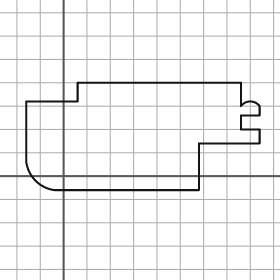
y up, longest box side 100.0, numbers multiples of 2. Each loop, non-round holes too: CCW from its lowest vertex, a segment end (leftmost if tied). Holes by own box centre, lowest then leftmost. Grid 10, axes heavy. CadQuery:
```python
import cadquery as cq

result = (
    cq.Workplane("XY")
    .moveTo(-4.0, -6.0)
    .lineTo(58.0, -6.0)
    .lineTo(58.0, 14.0)
    .lineTo(84.0, 14.0)
    .lineTo(84.0, 20.0)
    .lineTo(76.0, 20.0)
    .lineTo(76.0, 26.0)
    .lineTo(84.0, 26.0)
    .lineTo(84.0, 30.0)
    .threePointArc((80.0, 32.0), (76.0, 30.0))
    .lineTo(76.0, 40.0)
    .lineTo(6.0, 40.0)
    .lineTo(6.0, 32.0)
    .lineTo(-16.0, 32.0)
    .lineTo(-16.0, 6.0)
    .threePointArc((-12.0, -2.0), (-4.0, -6.0))
    .close()
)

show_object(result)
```